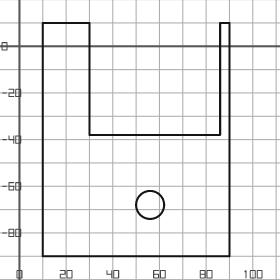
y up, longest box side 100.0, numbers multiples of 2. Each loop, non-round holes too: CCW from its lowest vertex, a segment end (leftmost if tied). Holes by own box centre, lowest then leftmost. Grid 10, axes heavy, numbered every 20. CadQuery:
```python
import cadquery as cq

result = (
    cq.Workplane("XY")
    .moveTo(10.0, -90.0)
    .lineTo(90.0, -90.0)
    .lineTo(90.0, 10.0)
    .lineTo(86.0, 10.0)
    .lineTo(86.0, -38.0)
    .lineTo(30.0, -38.0)
    .lineTo(30.0, 10.0)
    .lineTo(10.0, 10.0)
    .close()
    .moveTo(56.0, -68.0)
    .circle(6.0)
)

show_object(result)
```